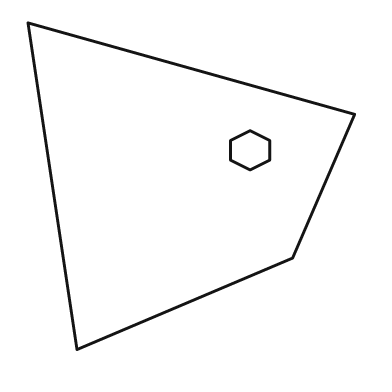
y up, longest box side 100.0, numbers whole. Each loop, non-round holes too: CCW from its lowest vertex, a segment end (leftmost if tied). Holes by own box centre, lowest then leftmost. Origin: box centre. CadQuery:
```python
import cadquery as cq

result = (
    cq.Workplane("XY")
    .moveTo(-35.0, -50.0)
    .lineTo(31.0, -22.0)
    .lineTo(50.0, 22.0)
    .lineTo(-50.0, 50.0)
    .close()
    .moveTo(18.0, 5.0)
    .lineTo(24.0, 8.0)
    .lineTo(24.0, 14.0)
    .lineTo(18.0, 17.0)
    .lineTo(12.0, 14.0)
    .lineTo(12.0, 8.0)
    .close()
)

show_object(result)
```